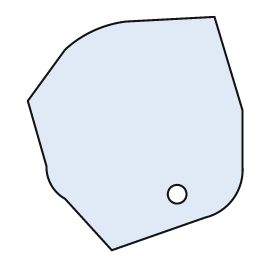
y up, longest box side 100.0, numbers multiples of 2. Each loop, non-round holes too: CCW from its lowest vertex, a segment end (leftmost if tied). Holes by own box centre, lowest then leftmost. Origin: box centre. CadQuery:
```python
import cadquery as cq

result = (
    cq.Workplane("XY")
    .moveTo(-10.0, -50.0)
    .lineTo(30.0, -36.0)
    .threePointArc((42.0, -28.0), (46.0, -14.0))
    .lineTo(46.0, 10.0)
    .lineTo(34.0, 50.0)
    .lineTo(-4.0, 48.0)
    .threePointArc((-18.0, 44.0), (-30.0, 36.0))
    .lineTo(-46.0, 14.0)
    .lineTo(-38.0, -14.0)
    .threePointArc((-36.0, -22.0), (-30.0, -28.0))
    .close()
    .moveTo(18.0, -26.0)
    .circle(4.0)
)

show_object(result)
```